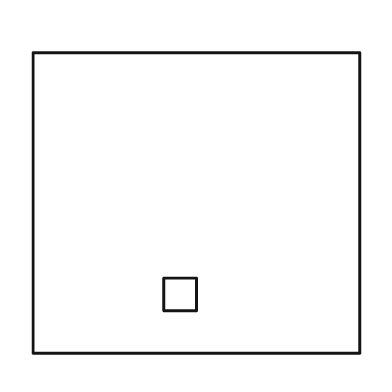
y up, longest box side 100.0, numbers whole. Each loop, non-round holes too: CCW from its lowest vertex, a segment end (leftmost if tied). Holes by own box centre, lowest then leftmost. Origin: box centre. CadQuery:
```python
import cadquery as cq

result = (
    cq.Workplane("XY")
    .moveTo(-50.0, -46.0)
    .lineTo(50.0, -46.0)
    .lineTo(50.0, 46.0)
    .lineTo(-50.0, 46.0)
    .close()
    .moveTo(-10.0, -33.0)
    .lineTo(0.0, -33.0)
    .lineTo(0.0, -23.0)
    .lineTo(-10.0, -23.0)
    .close()
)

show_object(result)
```